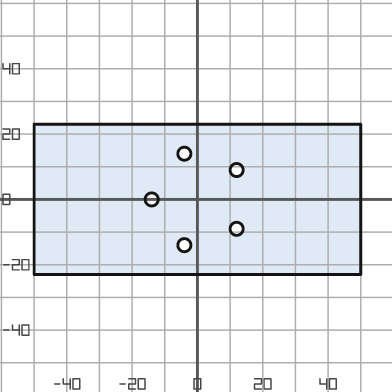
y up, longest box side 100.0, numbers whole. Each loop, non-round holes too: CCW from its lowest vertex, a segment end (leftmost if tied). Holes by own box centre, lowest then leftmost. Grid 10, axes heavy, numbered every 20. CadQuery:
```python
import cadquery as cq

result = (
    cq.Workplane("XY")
    .moveTo(-50.0, -23.0)
    .lineTo(50.0, -23.0)
    .lineTo(50.0, 23.0)
    .lineTo(-50.0, 23.0)
    .close()
    .moveTo(-4.0, -14.0)
    .circle(2.0)
    .moveTo(12.0, -9.0)
    .circle(2.0)
    .moveTo(-14.0, 0.0)
    .circle(2.0)
    .moveTo(12.0, 9.0)
    .circle(2.0)
    .moveTo(-4.0, 14.0)
    .circle(2.0)
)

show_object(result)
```